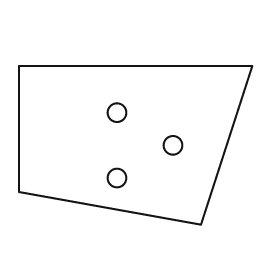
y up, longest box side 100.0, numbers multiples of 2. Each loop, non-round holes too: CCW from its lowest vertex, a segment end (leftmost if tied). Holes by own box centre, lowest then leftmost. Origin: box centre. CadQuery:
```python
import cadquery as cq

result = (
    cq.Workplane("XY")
    .moveTo(28.0, -34.0)
    .lineTo(50.0, 34.0)
    .lineTo(-50.0, 34.0)
    .lineTo(-50.0, -20.0)
    .close()
    .moveTo(-8.0, -14.0)
    .circle(4.0)
    .moveTo(16.0, 0.0)
    .circle(4.0)
    .moveTo(-8.0, 14.0)
    .circle(4.0)
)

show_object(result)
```